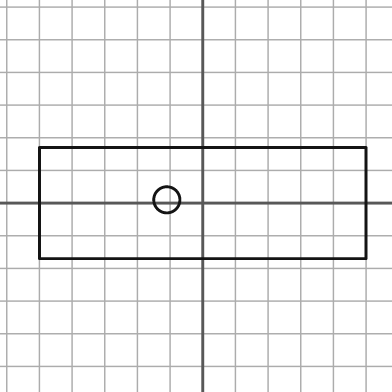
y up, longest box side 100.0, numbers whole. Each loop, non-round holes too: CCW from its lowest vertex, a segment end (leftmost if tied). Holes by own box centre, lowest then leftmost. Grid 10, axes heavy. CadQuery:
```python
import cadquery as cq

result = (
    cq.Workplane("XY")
    .moveTo(-50.0, -17.0)
    .lineTo(50.0, -17.0)
    .lineTo(50.0, 17.0)
    .lineTo(-50.0, 17.0)
    .close()
    .moveTo(-11.0, 1.0)
    .circle(4.0)
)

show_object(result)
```